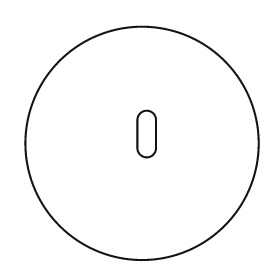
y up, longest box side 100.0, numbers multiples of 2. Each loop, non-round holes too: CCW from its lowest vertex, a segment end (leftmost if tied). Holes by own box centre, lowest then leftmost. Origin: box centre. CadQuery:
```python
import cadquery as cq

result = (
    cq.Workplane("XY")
    .moveTo(0.0, 0.0)
    .circle(50.0)
    .moveTo(-2.0, -2.0)
    .threePointArc((2.0, -6.0), (6.0, -2.0))
    .lineTo(6.0, 10.0)
    .threePointArc((2.0, 14.0), (-2.0, 10.0))
    .close()
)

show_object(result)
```